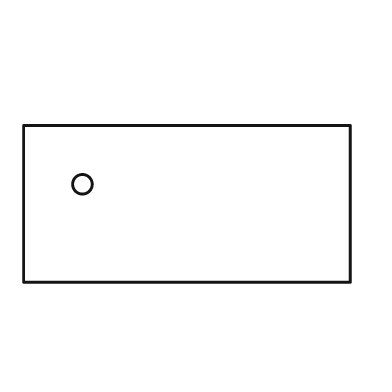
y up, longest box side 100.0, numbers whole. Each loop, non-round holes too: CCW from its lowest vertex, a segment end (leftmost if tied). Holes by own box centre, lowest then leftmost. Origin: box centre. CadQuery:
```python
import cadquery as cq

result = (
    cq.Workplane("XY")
    .moveTo(-50.0, -24.0)
    .lineTo(50.0, -24.0)
    .lineTo(50.0, 24.0)
    .lineTo(-50.0, 24.0)
    .close()
    .moveTo(-32.0, 6.0)
    .circle(3.0)
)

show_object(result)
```